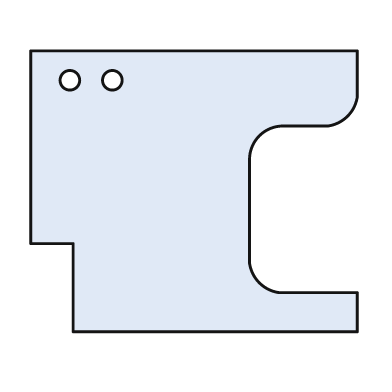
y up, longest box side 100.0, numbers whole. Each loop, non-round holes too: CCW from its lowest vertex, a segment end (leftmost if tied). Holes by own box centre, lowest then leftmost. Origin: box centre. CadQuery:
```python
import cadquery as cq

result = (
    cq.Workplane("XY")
    .moveTo(-37.0, -43.0)
    .lineTo(50.0, -43.0)
    .lineTo(50.0, -31.0)
    .lineTo(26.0, -31.0)
    .threePointArc((20.0, -28.0), (17.0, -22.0))
    .lineTo(17.0, 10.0)
    .threePointArc((20.0, 17.0), (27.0, 20.0))
    .lineTo(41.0, 20.0)
    .threePointArc((47.0, 23.0), (50.0, 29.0))
    .lineTo(50.0, 43.0)
    .lineTo(-50.0, 43.0)
    .lineTo(-50.0, -16.0)
    .lineTo(-37.0, -16.0)
    .close()
    .moveTo(-38.0, 34.0)
    .circle(3.0)
    .moveTo(-25.0, 34.0)
    .circle(3.0)
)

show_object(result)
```